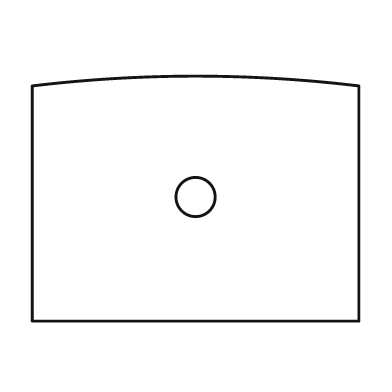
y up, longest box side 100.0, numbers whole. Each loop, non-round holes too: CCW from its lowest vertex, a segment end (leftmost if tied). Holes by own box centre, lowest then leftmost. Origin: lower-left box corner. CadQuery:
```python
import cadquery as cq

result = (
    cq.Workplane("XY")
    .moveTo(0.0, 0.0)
    .lineTo(100.0, 0.0)
    .lineTo(100.0, 72.0)
    .threePointArc((50.0, 75.0), (0.0, 72.0))
    .close()
    .moveTo(50.0, 38.0)
    .circle(6.0)
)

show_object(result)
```